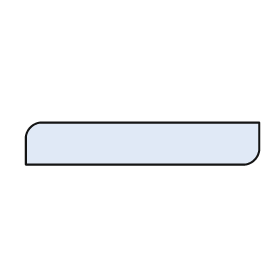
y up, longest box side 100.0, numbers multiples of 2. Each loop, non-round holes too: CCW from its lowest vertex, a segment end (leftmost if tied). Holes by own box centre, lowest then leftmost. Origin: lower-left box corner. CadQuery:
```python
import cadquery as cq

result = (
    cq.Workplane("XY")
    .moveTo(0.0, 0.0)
    .lineTo(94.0, 0.0)
    .threePointArc((98.0, 2.0), (100.0, 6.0))
    .lineTo(100.0, 18.0)
    .lineTo(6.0, 18.0)
    .threePointArc((2.0, 16.0), (0.0, 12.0))
    .close()
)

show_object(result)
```